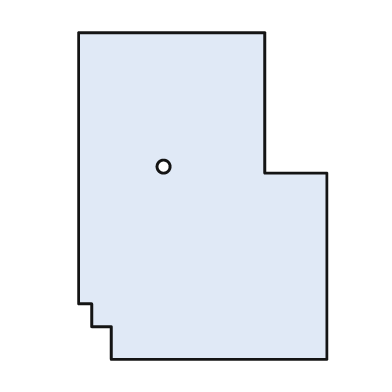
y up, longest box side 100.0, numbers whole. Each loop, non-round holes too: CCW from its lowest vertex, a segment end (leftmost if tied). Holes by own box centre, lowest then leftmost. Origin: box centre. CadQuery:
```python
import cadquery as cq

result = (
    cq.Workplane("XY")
    .moveTo(-28.0, -50.0)
    .lineTo(38.0, -50.0)
    .lineTo(38.0, 7.0)
    .lineTo(19.0, 7.0)
    .lineTo(19.0, 50.0)
    .lineTo(-38.0, 50.0)
    .lineTo(-38.0, -33.0)
    .lineTo(-34.0, -33.0)
    .lineTo(-34.0, -40.0)
    .lineTo(-28.0, -40.0)
    .close()
    .moveTo(-12.0, 9.0)
    .circle(2.0)
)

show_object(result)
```